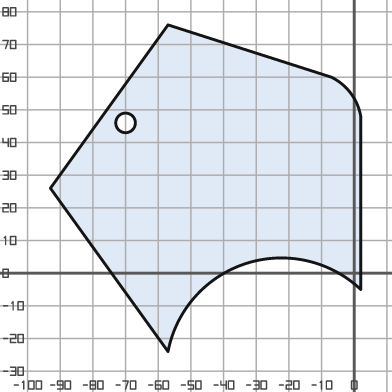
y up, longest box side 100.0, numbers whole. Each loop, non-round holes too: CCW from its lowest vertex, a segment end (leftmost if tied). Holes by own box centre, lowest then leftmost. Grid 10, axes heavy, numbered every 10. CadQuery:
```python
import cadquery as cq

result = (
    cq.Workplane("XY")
    .moveTo(-57.0, -24.0)
    .threePointArc((-33.0, 3.0), (2.0, -5.0))
    .lineTo(2.0, 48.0)
    .threePointArc((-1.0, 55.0), (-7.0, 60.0))
    .lineTo(-57.0, 76.0)
    .lineTo(-93.0, 26.0)
    .close()
    .moveTo(-70.0, 46.0)
    .circle(3.0)
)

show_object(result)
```